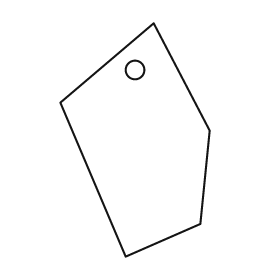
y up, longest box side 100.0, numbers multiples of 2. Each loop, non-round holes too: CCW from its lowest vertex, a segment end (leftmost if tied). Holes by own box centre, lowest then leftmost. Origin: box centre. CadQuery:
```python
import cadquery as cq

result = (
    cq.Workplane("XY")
    .moveTo(-4.0, -50.0)
    .lineTo(28.0, -36.0)
    .lineTo(32.0, 4.0)
    .lineTo(8.0, 50.0)
    .lineTo(-32.0, 16.0)
    .close()
    .moveTo(0.0, 30.0)
    .circle(4.0)
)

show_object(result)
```